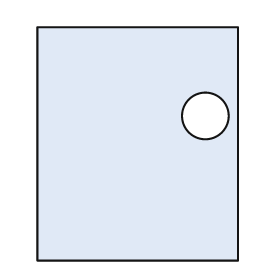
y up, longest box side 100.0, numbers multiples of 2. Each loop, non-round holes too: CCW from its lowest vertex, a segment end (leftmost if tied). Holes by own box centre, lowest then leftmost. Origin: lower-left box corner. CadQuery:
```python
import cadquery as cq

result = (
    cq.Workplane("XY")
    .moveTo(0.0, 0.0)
    .lineTo(86.0, 0.0)
    .lineTo(86.0, 100.0)
    .lineTo(0.0, 100.0)
    .close()
    .moveTo(72.0, 62.0)
    .circle(10.0)
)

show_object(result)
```